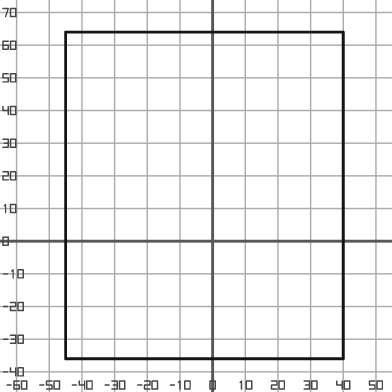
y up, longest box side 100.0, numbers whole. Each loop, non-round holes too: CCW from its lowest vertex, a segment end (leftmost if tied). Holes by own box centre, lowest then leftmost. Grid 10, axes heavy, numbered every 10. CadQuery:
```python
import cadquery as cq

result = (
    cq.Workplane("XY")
    .moveTo(-45.0, -36.0)
    .lineTo(40.0, -36.0)
    .lineTo(40.0, 64.0)
    .lineTo(-45.0, 64.0)
    .close()
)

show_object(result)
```